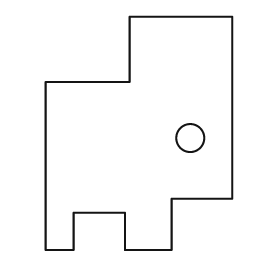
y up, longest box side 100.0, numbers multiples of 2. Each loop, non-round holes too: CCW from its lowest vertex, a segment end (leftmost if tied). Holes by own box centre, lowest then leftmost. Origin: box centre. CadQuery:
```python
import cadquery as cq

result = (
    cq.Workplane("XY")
    .moveTo(-40.0, -50.0)
    .lineTo(-28.0, -50.0)
    .lineTo(-28.0, -34.0)
    .lineTo(-6.0, -34.0)
    .lineTo(-6.0, -50.0)
    .lineTo(14.0, -50.0)
    .lineTo(14.0, -28.0)
    .lineTo(40.0, -28.0)
    .lineTo(40.0, 50.0)
    .lineTo(-4.0, 50.0)
    .lineTo(-4.0, 22.0)
    .lineTo(-40.0, 22.0)
    .close()
    .moveTo(22.0, -2.0)
    .circle(6.0)
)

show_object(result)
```